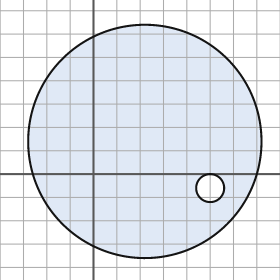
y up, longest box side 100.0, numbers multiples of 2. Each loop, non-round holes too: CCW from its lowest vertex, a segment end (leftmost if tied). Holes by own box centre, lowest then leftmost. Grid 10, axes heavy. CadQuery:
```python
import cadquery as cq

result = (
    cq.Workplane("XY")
    .moveTo(22.0, 14.0)
    .circle(50.0)
    .moveTo(50.0, -6.0)
    .circle(6.0)
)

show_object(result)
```